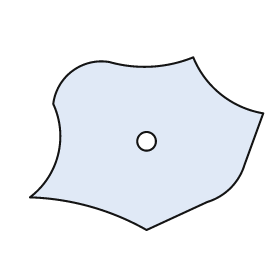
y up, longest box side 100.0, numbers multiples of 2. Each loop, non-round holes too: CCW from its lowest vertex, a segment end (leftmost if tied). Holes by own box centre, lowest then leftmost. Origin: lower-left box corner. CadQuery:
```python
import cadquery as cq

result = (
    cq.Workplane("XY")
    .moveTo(50.0, 0.0)
    .lineTo(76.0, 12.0)
    .threePointArc((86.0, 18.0), (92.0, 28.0))
    .lineTo(100.0, 50.0)
    .threePointArc((82.0, 58.0), (70.0, 74.0))
    .threePointArc((52.0, 70.0), (34.0, 72.0))
    .threePointArc((18.0, 68.0), (10.0, 54.0))
    .threePointArc((12.0, 32.0), (0.0, 14.0))
    .threePointArc((26.0, 10.0), (50.0, 0.0))
    .close()
    .moveTo(50.0, 38.0)
    .circle(4.0)
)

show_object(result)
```